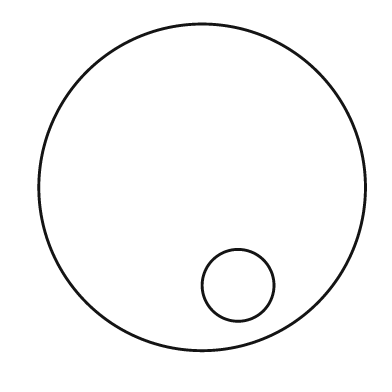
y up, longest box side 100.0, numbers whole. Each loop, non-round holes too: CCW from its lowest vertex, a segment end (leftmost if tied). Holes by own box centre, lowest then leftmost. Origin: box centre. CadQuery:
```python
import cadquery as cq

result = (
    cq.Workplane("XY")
    .moveTo(0.0, 0.0)
    .circle(50.0)
    .moveTo(11.0, -30.0)
    .circle(11.0)
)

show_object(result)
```